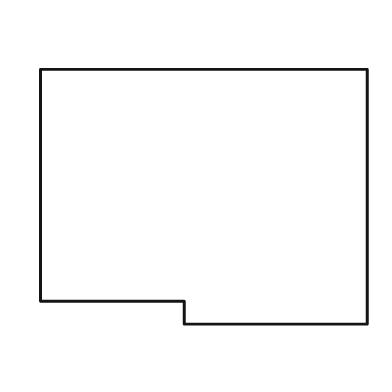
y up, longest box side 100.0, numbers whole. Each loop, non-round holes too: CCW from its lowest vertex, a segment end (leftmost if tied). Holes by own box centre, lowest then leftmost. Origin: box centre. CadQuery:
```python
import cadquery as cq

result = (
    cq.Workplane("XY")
    .moveTo(-6.0, -39.0)
    .lineTo(50.0, -39.0)
    .lineTo(50.0, 39.0)
    .lineTo(-50.0, 39.0)
    .lineTo(-50.0, -32.0)
    .lineTo(-6.0, -32.0)
    .close()
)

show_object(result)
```